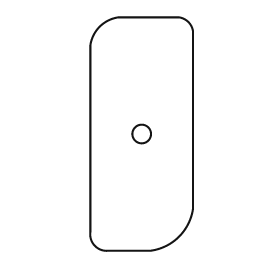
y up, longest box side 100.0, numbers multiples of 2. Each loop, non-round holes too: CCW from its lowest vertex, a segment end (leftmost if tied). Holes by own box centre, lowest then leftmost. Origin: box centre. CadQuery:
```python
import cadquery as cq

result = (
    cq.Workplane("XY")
    .moveTo(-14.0, -50.0)
    .lineTo(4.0, -50.0)
    .threePointArc((16.0, -44.0), (22.0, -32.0))
    .lineTo(22.0, 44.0)
    .threePointArc((20.0, 48.0), (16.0, 50.0))
    .lineTo(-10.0, 50.0)
    .threePointArc((-18.0, 46.0), (-22.0, 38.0))
    .lineTo(-22.0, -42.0)
    .threePointArc((-20.0, -48.0), (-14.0, -50.0))
    .close()
    .moveTo(0.0, 0.0)
    .circle(4.0)
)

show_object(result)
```